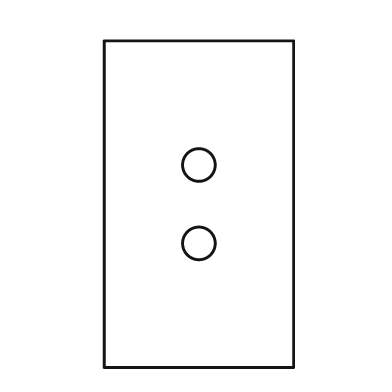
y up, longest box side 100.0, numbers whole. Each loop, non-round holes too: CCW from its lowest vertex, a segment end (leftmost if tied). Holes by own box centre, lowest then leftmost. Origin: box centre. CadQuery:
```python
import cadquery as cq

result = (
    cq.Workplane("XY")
    .moveTo(-29.0, -50.0)
    .lineTo(29.0, -50.0)
    .lineTo(29.0, 50.0)
    .lineTo(-29.0, 50.0)
    .close()
    .moveTo(0.0, -12.0)
    .circle(5.0)
    .moveTo(0.0, 12.0)
    .circle(5.0)
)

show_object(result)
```